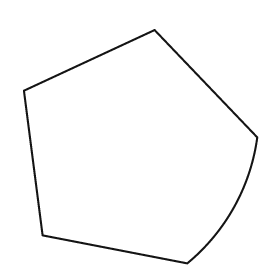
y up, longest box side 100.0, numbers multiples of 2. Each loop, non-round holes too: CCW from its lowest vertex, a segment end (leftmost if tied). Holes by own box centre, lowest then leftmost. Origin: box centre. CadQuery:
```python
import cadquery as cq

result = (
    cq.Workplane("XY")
    .moveTo(20.0, -50.0)
    .threePointArc((40.0, -26.0), (50.0, 4.0))
    .lineTo(6.0, 50.0)
    .lineTo(-50.0, 24.0)
    .lineTo(-42.0, -38.0)
    .close()
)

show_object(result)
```